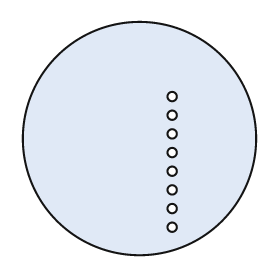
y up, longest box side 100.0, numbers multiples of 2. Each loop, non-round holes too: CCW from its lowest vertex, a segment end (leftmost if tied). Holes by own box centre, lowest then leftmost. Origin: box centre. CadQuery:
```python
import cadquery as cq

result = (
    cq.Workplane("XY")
    .moveTo(0.0, 0.0)
    .circle(50.0)
    .moveTo(14.0, -38.0)
    .circle(2.0)
    .moveTo(14.0, -30.0)
    .circle(2.0)
    .moveTo(14.0, -22.0)
    .circle(2.0)
    .moveTo(14.0, -14.0)
    .circle(2.0)
    .moveTo(14.0, -6.0)
    .circle(2.0)
    .moveTo(14.0, 2.0)
    .circle(2.0)
    .moveTo(14.0, 10.0)
    .circle(2.0)
    .moveTo(14.0, 18.0)
    .circle(2.0)
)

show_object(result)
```